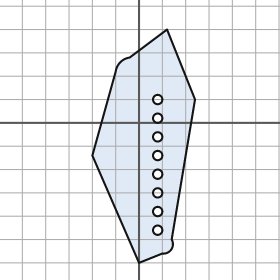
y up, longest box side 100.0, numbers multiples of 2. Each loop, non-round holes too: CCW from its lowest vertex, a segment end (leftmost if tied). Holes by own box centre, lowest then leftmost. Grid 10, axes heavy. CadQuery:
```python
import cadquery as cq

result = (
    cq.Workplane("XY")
    .moveTo(0.0, -60.0)
    .lineTo(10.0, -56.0)
    .threePointArc((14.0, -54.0), (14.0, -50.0))
    .lineTo(24.0, 10.0)
    .lineTo(12.0, 40.0)
    .lineTo(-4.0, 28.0)
    .threePointArc((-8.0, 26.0), (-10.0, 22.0))
    .lineTo(-20.0, -14.0)
    .close()
    .moveTo(8.0, -46.0)
    .circle(2.0)
    .moveTo(8.0, -38.0)
    .circle(2.0)
    .moveTo(8.0, -30.0)
    .circle(2.0)
    .moveTo(8.0, -22.0)
    .circle(2.0)
    .moveTo(8.0, -14.0)
    .circle(2.0)
    .moveTo(8.0, -6.0)
    .circle(2.0)
    .moveTo(8.0, 2.0)
    .circle(2.0)
    .moveTo(8.0, 10.0)
    .circle(2.0)
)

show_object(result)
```